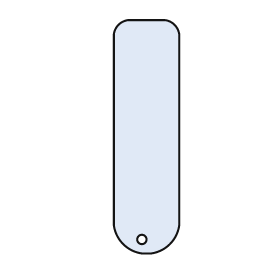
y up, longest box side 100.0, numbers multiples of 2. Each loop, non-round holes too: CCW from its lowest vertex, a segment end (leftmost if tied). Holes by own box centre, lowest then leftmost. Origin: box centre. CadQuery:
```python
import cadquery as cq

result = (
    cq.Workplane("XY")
    .moveTo(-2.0, -50.0)
    .lineTo(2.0, -50.0)
    .threePointArc((10.0, -46.0), (14.0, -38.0))
    .lineTo(14.0, 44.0)
    .threePointArc((12.0, 48.0), (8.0, 50.0))
    .lineTo(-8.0, 50.0)
    .threePointArc((-12.0, 48.0), (-14.0, 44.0))
    .lineTo(-14.0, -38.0)
    .threePointArc((-10.0, -46.0), (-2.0, -50.0))
    .close()
    .moveTo(-2.0, -44.0)
    .circle(2.0)
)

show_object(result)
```